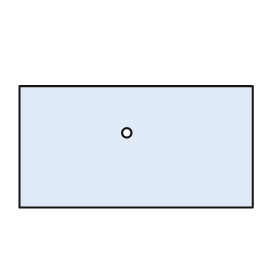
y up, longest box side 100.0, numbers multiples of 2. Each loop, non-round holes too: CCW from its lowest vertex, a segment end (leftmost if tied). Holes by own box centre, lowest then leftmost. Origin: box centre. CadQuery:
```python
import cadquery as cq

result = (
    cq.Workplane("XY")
    .moveTo(-50.0, -26.0)
    .lineTo(50.0, -26.0)
    .lineTo(50.0, 26.0)
    .lineTo(-50.0, 26.0)
    .close()
    .moveTo(-4.0, 6.0)
    .circle(2.0)
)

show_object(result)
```